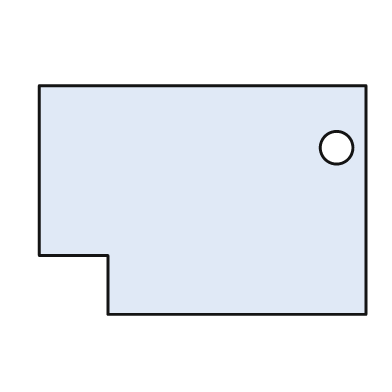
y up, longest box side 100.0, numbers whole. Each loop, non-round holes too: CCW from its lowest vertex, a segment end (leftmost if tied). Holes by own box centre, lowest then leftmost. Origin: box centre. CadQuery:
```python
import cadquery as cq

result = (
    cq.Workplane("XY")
    .moveTo(-29.0, -35.0)
    .lineTo(50.0, -35.0)
    .lineTo(50.0, 35.0)
    .lineTo(-50.0, 35.0)
    .lineTo(-50.0, -17.0)
    .lineTo(-29.0, -17.0)
    .close()
    .moveTo(41.0, 16.0)
    .circle(5.0)
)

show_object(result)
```